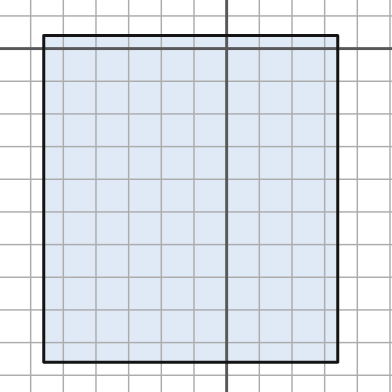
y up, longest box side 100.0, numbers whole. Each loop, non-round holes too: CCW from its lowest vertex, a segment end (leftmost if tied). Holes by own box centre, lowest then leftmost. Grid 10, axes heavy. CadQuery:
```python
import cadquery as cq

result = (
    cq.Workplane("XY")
    .moveTo(-56.0, -96.0)
    .lineTo(34.0, -96.0)
    .lineTo(34.0, 4.0)
    .lineTo(-56.0, 4.0)
    .close()
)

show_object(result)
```